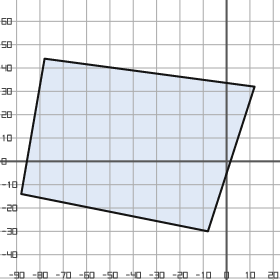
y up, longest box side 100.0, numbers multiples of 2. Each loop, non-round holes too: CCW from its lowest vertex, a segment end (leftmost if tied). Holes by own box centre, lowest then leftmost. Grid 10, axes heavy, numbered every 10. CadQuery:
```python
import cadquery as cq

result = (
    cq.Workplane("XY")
    .moveTo(-8.0, -30.0)
    .lineTo(12.0, 32.0)
    .lineTo(-78.0, 44.0)
    .lineTo(-88.0, -14.0)
    .close()
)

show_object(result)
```